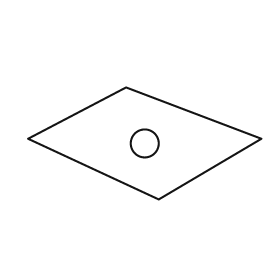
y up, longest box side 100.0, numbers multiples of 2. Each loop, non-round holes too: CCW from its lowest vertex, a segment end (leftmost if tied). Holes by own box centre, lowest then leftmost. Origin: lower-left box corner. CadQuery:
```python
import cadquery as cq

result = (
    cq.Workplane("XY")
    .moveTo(56.0, 0.0)
    .lineTo(100.0, 26.0)
    .lineTo(42.0, 48.0)
    .lineTo(0.0, 26.0)
    .close()
    .moveTo(50.0, 24.0)
    .circle(6.0)
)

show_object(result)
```